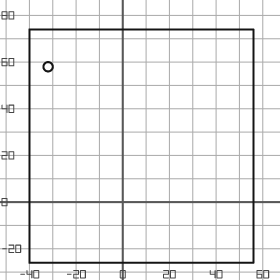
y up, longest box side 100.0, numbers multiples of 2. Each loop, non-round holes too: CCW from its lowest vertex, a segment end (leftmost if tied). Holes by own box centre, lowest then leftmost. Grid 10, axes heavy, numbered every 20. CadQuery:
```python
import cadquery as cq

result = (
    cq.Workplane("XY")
    .moveTo(-40.0, -26.0)
    .lineTo(56.0, -26.0)
    .lineTo(56.0, 74.0)
    .lineTo(-40.0, 74.0)
    .close()
    .moveTo(-32.0, 58.0)
    .circle(2.0)
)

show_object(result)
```